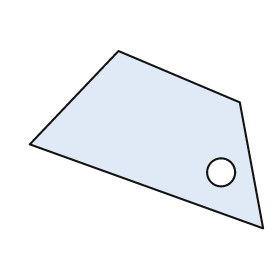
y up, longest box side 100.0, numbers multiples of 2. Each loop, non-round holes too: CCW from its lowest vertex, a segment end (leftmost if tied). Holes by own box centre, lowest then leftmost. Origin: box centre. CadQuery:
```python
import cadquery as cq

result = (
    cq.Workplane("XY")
    .moveTo(50.0, -38.0)
    .lineTo(40.0, 16.0)
    .lineTo(-12.0, 38.0)
    .lineTo(-50.0, -2.0)
    .close()
    .moveTo(32.0, -14.0)
    .circle(6.0)
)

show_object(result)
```